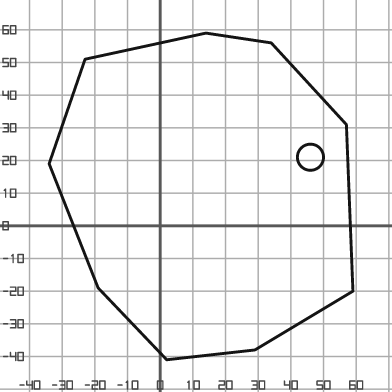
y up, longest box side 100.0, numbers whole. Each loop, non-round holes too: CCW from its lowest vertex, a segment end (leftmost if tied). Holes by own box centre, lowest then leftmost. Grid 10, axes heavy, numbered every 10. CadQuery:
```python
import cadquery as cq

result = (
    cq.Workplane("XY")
    .moveTo(2.0, -41.0)
    .lineTo(29.0, -38.0)
    .lineTo(59.0, -20.0)
    .lineTo(57.0, 31.0)
    .lineTo(34.0, 56.0)
    .lineTo(14.0, 59.0)
    .lineTo(-23.0, 51.0)
    .lineTo(-34.0, 19.0)
    .lineTo(-19.0, -19.0)
    .close()
    .moveTo(46.0, 21.0)
    .circle(4.0)
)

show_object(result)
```